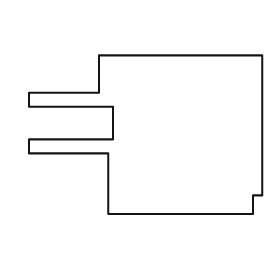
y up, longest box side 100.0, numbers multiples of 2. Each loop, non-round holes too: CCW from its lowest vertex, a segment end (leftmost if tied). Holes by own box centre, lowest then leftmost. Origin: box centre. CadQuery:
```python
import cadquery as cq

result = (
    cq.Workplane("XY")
    .moveTo(-16.0, -34.0)
    .lineTo(46.0, -34.0)
    .lineTo(46.0, -26.0)
    .lineTo(50.0, -26.0)
    .lineTo(50.0, 34.0)
    .lineTo(-20.0, 34.0)
    .lineTo(-20.0, 18.0)
    .lineTo(-50.0, 18.0)
    .lineTo(-50.0, 12.0)
    .lineTo(-14.0, 12.0)
    .lineTo(-14.0, -2.0)
    .lineTo(-50.0, -2.0)
    .lineTo(-50.0, -8.0)
    .lineTo(-16.0, -8.0)
    .close()
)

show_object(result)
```